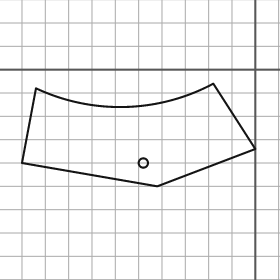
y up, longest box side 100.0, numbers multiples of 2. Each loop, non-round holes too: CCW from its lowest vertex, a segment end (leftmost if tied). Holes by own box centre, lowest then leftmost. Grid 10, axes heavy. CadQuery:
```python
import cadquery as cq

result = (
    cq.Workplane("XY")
    .moveTo(-42.0, -50.0)
    .lineTo(0.0, -34.0)
    .lineTo(-18.0, -6.0)
    .threePointArc((-56.0, -16.0), (-94.0, -8.0))
    .lineTo(-100.0, -40.0)
    .close()
    .moveTo(-48.0, -40.0)
    .circle(2.0)
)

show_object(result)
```